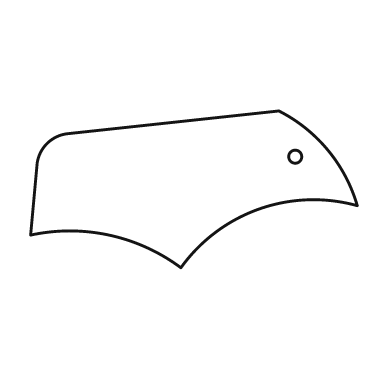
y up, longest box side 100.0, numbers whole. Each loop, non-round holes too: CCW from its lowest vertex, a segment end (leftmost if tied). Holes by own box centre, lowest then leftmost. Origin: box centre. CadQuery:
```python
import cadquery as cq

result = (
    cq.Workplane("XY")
    .moveTo(-4.0, -24.0)
    .threePointArc((20.0, -6.0), (50.0, -5.0))
    .threePointArc((41.0, 12.0), (26.0, 24.0))
    .lineTo(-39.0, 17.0)
    .threePointArc((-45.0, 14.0), (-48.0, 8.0))
    .lineTo(-50.0, -14.0)
    .threePointArc((-26.0, -14.0), (-4.0, -24.0))
    .close()
    .moveTo(31.0, 10.0)
    .circle(2.0)
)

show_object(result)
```